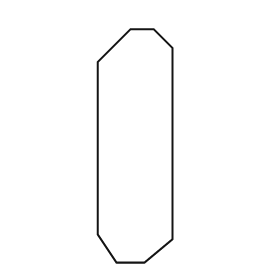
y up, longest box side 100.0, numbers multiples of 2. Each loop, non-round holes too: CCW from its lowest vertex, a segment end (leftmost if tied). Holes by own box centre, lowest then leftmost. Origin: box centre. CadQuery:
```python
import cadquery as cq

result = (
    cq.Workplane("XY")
    .moveTo(-8.0, -50.0)
    .lineTo(4.0, -50.0)
    .lineTo(16.0, -40.0)
    .lineTo(16.0, 42.0)
    .lineTo(8.0, 50.0)
    .lineTo(-2.0, 50.0)
    .lineTo(-16.0, 36.0)
    .lineTo(-16.0, -38.0)
    .close()
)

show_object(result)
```